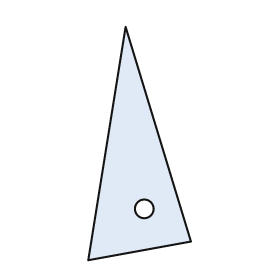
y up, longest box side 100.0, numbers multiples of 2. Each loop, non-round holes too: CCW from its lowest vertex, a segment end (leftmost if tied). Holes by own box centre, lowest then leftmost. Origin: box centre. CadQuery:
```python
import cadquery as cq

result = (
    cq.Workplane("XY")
    .moveTo(-22.0, -50.0)
    .lineTo(22.0, -42.0)
    .lineTo(-6.0, 50.0)
    .close()
    .moveTo(2.0, -28.0)
    .circle(4.0)
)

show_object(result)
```